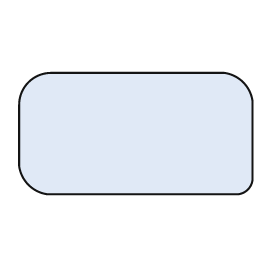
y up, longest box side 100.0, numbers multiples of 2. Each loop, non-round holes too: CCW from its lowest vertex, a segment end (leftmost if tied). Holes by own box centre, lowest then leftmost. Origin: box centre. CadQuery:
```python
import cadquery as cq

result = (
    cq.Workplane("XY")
    .moveTo(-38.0, -26.0)
    .lineTo(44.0, -26.0)
    .threePointArc((48.0, -24.0), (50.0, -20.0))
    .lineTo(50.0, 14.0)
    .threePointArc((46.0, 22.0), (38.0, 26.0))
    .lineTo(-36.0, 26.0)
    .threePointArc((-46.0, 22.0), (-50.0, 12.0))
    .lineTo(-50.0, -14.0)
    .threePointArc((-46.0, -22.0), (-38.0, -26.0))
    .close()
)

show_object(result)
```